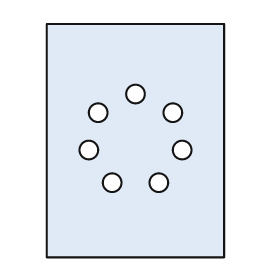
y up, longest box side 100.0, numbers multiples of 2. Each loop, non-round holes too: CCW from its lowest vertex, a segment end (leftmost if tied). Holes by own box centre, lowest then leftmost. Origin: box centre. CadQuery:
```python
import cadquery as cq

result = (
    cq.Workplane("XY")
    .moveTo(-38.0, -50.0)
    .lineTo(38.0, -50.0)
    .lineTo(38.0, 50.0)
    .lineTo(-38.0, 50.0)
    .close()
    .moveTo(-10.0, -18.0)
    .circle(4.0)
    .moveTo(10.0, -18.0)
    .circle(4.0)
    .moveTo(-20.0, -4.0)
    .circle(4.0)
    .moveTo(20.0, -4.0)
    .circle(4.0)
    .moveTo(-16.0, 12.0)
    .circle(4.0)
    .moveTo(16.0, 12.0)
    .circle(4.0)
    .moveTo(0.0, 20.0)
    .circle(4.0)
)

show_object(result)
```